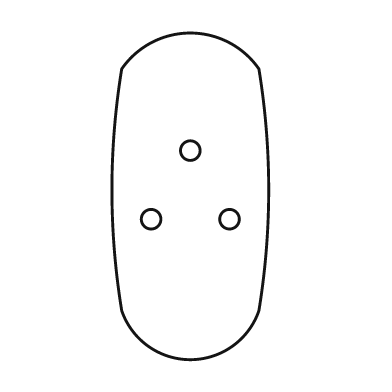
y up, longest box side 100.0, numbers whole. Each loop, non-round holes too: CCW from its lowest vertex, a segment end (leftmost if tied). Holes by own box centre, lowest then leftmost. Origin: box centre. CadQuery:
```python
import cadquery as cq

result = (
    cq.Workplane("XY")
    .moveTo(-21.0, -35.0)
    .threePointArc((0.0, -50.0), (21.0, -35.0))
    .threePointArc((24.0, 2.0), (21.0, 39.0))
    .threePointArc((0.0, 50.0), (-21.0, 39.0))
    .threePointArc((-24.0, 2.0), (-21.0, -35.0))
    .close()
    .moveTo(-12.0, -7.0)
    .circle(3.0)
    .moveTo(12.0, -7.0)
    .circle(3.0)
    .moveTo(0.0, 14.0)
    .circle(3.0)
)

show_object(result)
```